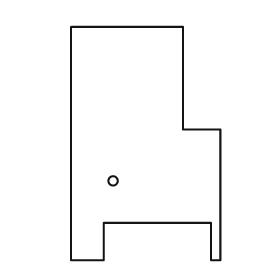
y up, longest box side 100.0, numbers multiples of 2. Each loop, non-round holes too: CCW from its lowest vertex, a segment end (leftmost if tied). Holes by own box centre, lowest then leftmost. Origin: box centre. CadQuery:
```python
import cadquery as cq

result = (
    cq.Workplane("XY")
    .moveTo(-32.0, -50.0)
    .lineTo(-18.0, -50.0)
    .lineTo(-18.0, -34.0)
    .lineTo(28.0, -34.0)
    .lineTo(28.0, -50.0)
    .lineTo(32.0, -50.0)
    .lineTo(32.0, 6.0)
    .lineTo(16.0, 6.0)
    .lineTo(16.0, 50.0)
    .lineTo(-32.0, 50.0)
    .close()
    .moveTo(-14.0, -16.0)
    .circle(2.0)
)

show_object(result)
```